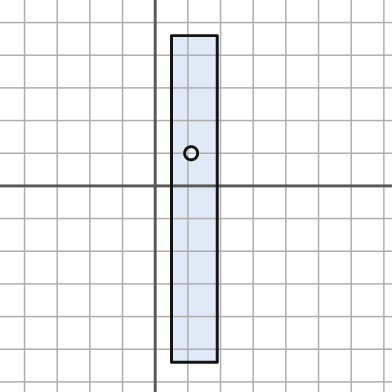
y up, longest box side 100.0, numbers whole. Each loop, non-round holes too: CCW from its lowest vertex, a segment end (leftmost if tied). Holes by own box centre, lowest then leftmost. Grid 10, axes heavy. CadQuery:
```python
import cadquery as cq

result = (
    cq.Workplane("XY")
    .moveTo(5.0, -54.0)
    .lineTo(19.0, -54.0)
    .lineTo(19.0, 46.0)
    .lineTo(5.0, 46.0)
    .close()
    .moveTo(11.0, 10.0)
    .circle(2.0)
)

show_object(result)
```